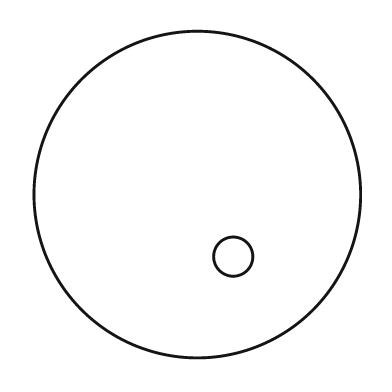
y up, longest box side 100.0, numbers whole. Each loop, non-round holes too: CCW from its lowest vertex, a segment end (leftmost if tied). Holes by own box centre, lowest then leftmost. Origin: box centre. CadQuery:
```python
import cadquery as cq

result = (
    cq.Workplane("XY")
    .moveTo(0.0, 0.0)
    .circle(50.0)
    .moveTo(11.0, -19.0)
    .circle(6.0)
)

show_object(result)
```